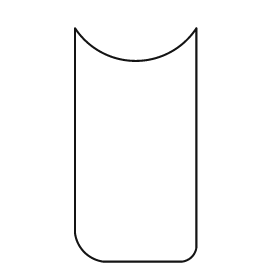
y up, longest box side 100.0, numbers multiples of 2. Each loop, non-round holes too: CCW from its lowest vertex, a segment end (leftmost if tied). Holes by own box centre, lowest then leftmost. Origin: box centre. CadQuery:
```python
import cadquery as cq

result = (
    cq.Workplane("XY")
    .moveTo(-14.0, -50.0)
    .lineTo(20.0, -50.0)
    .threePointArc((24.0, -48.0), (26.0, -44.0))
    .lineTo(26.0, 50.0)
    .threePointArc((0.0, 36.0), (-26.0, 50.0))
    .lineTo(-26.0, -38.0)
    .threePointArc((-22.0, -46.0), (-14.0, -50.0))
    .close()
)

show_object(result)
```